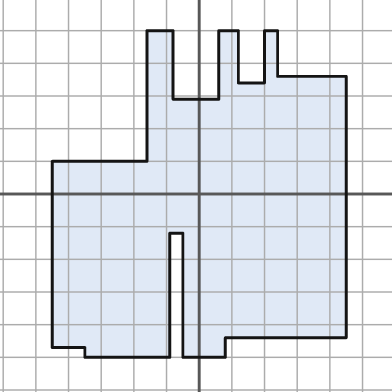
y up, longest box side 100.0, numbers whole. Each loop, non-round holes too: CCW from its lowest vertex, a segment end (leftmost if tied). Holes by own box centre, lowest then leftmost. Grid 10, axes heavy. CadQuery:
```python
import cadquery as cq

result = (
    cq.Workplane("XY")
    .moveTo(-35.0, -50.0)
    .lineTo(-9.0, -50.0)
    .lineTo(-9.0, -12.0)
    .lineTo(-5.0, -12.0)
    .lineTo(-5.0, -50.0)
    .lineTo(8.0, -50.0)
    .lineTo(8.0, -44.0)
    .lineTo(45.0, -44.0)
    .lineTo(45.0, 36.0)
    .lineTo(24.0, 36.0)
    .lineTo(24.0, 50.0)
    .lineTo(20.0, 50.0)
    .lineTo(20.0, 34.0)
    .lineTo(12.0, 34.0)
    .lineTo(12.0, 50.0)
    .lineTo(6.0, 50.0)
    .lineTo(6.0, 29.0)
    .lineTo(-8.0, 29.0)
    .lineTo(-8.0, 50.0)
    .lineTo(-16.0, 50.0)
    .lineTo(-16.0, 10.0)
    .lineTo(-45.0, 10.0)
    .lineTo(-45.0, -47.0)
    .lineTo(-35.0, -47.0)
    .close()
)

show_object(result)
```